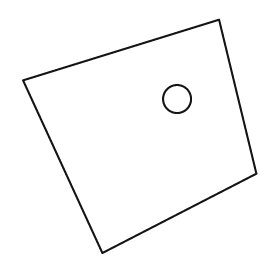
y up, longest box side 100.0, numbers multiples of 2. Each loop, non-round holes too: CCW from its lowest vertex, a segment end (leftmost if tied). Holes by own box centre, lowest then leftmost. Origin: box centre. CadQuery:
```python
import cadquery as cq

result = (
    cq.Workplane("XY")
    .moveTo(-16.0, -50.0)
    .lineTo(50.0, -16.0)
    .lineTo(34.0, 50.0)
    .lineTo(-50.0, 24.0)
    .close()
    .moveTo(16.0, 16.0)
    .circle(6.0)
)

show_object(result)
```